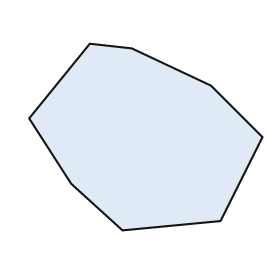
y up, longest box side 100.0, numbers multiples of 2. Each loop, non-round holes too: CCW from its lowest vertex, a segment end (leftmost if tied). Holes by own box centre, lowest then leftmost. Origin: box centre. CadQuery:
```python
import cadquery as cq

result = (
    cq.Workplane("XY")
    .moveTo(-10.0, -40.0)
    .lineTo(32.0, -36.0)
    .lineTo(50.0, 0.0)
    .lineTo(28.0, 22.0)
    .lineTo(-6.0, 38.0)
    .lineTo(-24.0, 40.0)
    .lineTo(-50.0, 8.0)
    .lineTo(-32.0, -20.0)
    .close()
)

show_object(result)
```